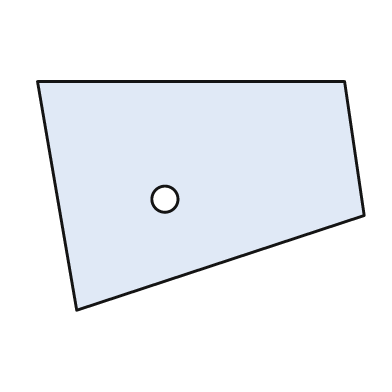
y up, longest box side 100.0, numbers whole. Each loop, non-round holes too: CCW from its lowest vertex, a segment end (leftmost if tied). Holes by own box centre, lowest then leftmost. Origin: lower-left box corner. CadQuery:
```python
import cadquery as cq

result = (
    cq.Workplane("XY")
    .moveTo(12.0, 0.0)
    .lineTo(100.0, 29.0)
    .lineTo(94.0, 70.0)
    .lineTo(0.0, 70.0)
    .close()
    .moveTo(39.0, 34.0)
    .circle(4.0)
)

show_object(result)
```